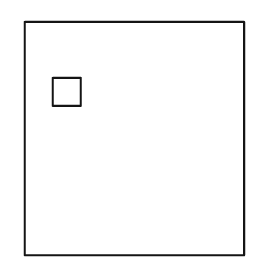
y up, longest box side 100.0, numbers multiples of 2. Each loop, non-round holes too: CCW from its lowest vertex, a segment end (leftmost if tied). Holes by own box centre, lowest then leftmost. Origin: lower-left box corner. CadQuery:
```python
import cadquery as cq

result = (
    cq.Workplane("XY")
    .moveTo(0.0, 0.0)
    .lineTo(94.0, 0.0)
    .lineTo(94.0, 100.0)
    .lineTo(0.0, 100.0)
    .close()
    .moveTo(12.0, 64.0)
    .lineTo(24.0, 64.0)
    .lineTo(24.0, 76.0)
    .lineTo(12.0, 76.0)
    .close()
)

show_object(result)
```